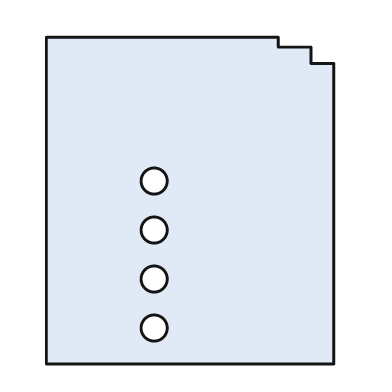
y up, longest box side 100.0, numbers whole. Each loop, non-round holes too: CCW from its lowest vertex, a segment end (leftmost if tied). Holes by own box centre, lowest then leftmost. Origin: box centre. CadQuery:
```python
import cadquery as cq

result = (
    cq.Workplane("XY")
    .moveTo(-44.0, -50.0)
    .lineTo(44.0, -50.0)
    .lineTo(44.0, 42.0)
    .lineTo(37.0, 42.0)
    .lineTo(37.0, 47.0)
    .lineTo(27.0, 47.0)
    .lineTo(27.0, 50.0)
    .lineTo(-44.0, 50.0)
    .close()
    .moveTo(-11.0, -39.0)
    .circle(4.0)
    .moveTo(-11.0, -24.0)
    .circle(4.0)
    .moveTo(-11.0, -9.0)
    .circle(4.0)
    .moveTo(-11.0, 6.0)
    .circle(4.0)
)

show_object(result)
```